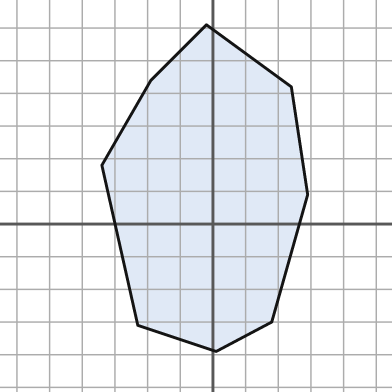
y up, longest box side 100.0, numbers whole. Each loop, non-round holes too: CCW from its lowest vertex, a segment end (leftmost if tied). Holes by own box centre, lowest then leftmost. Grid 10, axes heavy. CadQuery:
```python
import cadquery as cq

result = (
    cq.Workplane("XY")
    .moveTo(1.0, -39.0)
    .lineTo(18.0, -30.0)
    .lineTo(29.0, 9.0)
    .lineTo(24.0, 42.0)
    .lineTo(-2.0, 61.0)
    .lineTo(-19.0, 44.0)
    .lineTo(-34.0, 18.0)
    .lineTo(-23.0, -31.0)
    .close()
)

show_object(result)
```